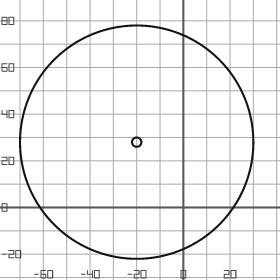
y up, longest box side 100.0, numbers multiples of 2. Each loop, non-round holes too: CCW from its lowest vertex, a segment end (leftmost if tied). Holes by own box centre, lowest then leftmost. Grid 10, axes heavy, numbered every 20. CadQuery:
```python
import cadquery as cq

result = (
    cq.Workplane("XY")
    .moveTo(-20.0, 28.0)
    .circle(50.0)
    .moveTo(-20.0, 28.0)
    .circle(2.0)
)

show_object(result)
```